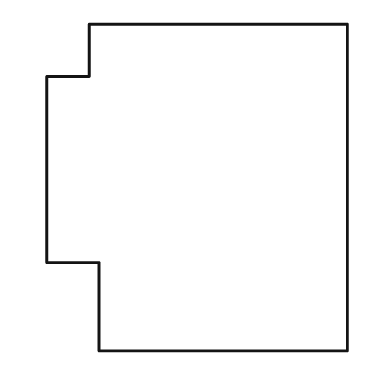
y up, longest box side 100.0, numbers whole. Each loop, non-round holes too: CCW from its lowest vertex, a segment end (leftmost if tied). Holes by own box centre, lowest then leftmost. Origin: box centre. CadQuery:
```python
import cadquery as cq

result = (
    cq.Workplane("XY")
    .moveTo(-30.0, -50.0)
    .lineTo(46.0, -50.0)
    .lineTo(46.0, 50.0)
    .lineTo(-33.0, 50.0)
    .lineTo(-33.0, 34.0)
    .lineTo(-46.0, 34.0)
    .lineTo(-46.0, -23.0)
    .lineTo(-30.0, -23.0)
    .close()
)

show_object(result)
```